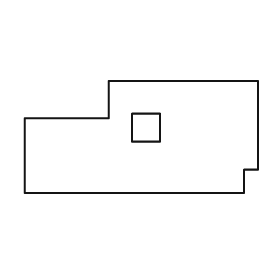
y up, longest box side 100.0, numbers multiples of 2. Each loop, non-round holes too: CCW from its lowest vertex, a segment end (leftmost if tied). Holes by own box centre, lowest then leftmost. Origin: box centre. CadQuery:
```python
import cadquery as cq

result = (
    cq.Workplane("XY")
    .moveTo(-50.0, -24.0)
    .lineTo(44.0, -24.0)
    .lineTo(44.0, -14.0)
    .lineTo(50.0, -14.0)
    .lineTo(50.0, 24.0)
    .lineTo(-14.0, 24.0)
    .lineTo(-14.0, 8.0)
    .lineTo(-50.0, 8.0)
    .close()
    .moveTo(-4.0, -2.0)
    .lineTo(8.0, -2.0)
    .lineTo(8.0, 10.0)
    .lineTo(-4.0, 10.0)
    .close()
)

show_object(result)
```